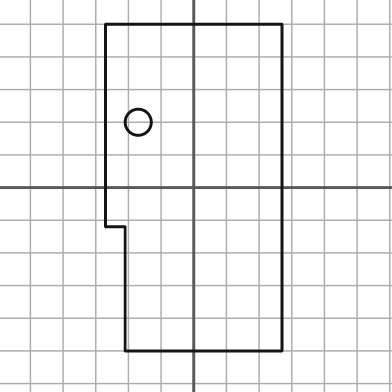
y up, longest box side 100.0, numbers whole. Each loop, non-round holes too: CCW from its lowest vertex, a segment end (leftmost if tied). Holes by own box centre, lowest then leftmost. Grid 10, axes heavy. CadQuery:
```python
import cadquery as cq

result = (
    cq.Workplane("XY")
    .moveTo(-21.0, -50.0)
    .lineTo(27.0, -50.0)
    .lineTo(27.0, 50.0)
    .lineTo(-27.0, 50.0)
    .lineTo(-27.0, -12.0)
    .lineTo(-21.0, -12.0)
    .close()
    .moveTo(-17.0, 20.0)
    .circle(4.0)
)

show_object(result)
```